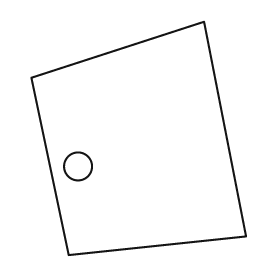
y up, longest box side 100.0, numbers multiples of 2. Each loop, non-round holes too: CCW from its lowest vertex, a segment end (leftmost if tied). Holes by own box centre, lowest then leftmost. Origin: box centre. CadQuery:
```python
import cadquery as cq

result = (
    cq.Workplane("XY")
    .moveTo(-30.0, -50.0)
    .lineTo(46.0, -42.0)
    .lineTo(28.0, 50.0)
    .lineTo(-46.0, 26.0)
    .close()
    .moveTo(-26.0, -12.0)
    .circle(6.0)
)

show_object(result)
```